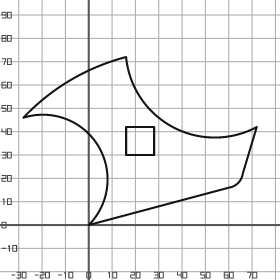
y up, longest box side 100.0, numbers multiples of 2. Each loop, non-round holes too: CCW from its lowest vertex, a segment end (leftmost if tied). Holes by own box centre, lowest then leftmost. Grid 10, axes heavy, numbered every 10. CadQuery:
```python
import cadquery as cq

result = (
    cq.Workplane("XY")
    .moveTo(0.0, 0.0)
    .lineTo(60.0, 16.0)
    .threePointArc((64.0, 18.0), (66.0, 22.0))
    .lineTo(72.0, 42.0)
    .threePointArc((36.0, 42.0), (16.0, 72.0))
    .threePointArc((-8.0, 62.0), (-28.0, 46.0))
    .threePointArc((4.0, 34.0), (0.0, 0.0))
    .close()
    .moveTo(16.0, 30.0)
    .lineTo(28.0, 30.0)
    .lineTo(28.0, 42.0)
    .lineTo(16.0, 42.0)
    .close()
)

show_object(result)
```